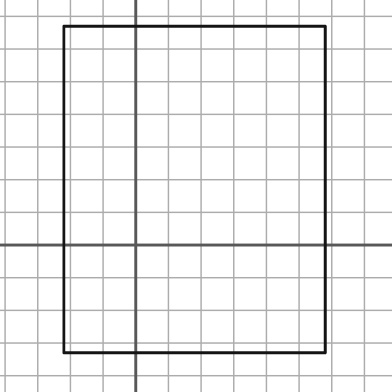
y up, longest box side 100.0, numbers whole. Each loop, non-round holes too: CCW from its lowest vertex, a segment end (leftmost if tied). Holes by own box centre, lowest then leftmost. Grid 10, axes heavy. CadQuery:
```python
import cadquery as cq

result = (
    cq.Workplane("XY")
    .moveTo(-22.0, -33.0)
    .lineTo(58.0, -33.0)
    .lineTo(58.0, 67.0)
    .lineTo(-22.0, 67.0)
    .close()
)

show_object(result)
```